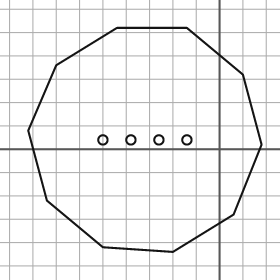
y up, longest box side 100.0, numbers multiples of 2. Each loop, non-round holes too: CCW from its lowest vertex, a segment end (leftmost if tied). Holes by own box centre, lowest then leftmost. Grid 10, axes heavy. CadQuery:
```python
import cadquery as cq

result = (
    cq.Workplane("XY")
    .moveTo(-20.0, -44.0)
    .lineTo(6.0, -28.0)
    .lineTo(18.0, 2.0)
    .lineTo(10.0, 32.0)
    .lineTo(-14.0, 52.0)
    .lineTo(-44.0, 52.0)
    .lineTo(-70.0, 36.0)
    .lineTo(-82.0, 8.0)
    .lineTo(-74.0, -22.0)
    .lineTo(-50.0, -42.0)
    .close()
    .moveTo(-50.0, 4.0)
    .circle(2.0)
    .moveTo(-38.0, 4.0)
    .circle(2.0)
    .moveTo(-26.0, 4.0)
    .circle(2.0)
    .moveTo(-14.0, 4.0)
    .circle(2.0)
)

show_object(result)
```